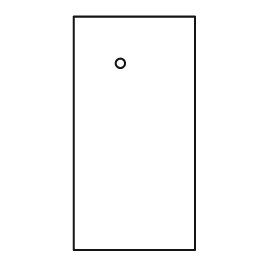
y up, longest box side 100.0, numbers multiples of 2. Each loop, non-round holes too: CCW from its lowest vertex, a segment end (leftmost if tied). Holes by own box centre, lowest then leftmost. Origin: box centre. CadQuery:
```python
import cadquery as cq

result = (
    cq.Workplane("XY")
    .moveTo(-26.0, -50.0)
    .lineTo(26.0, -50.0)
    .lineTo(26.0, 50.0)
    .lineTo(-26.0, 50.0)
    .close()
    .moveTo(-6.0, 30.0)
    .circle(2.0)
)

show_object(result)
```